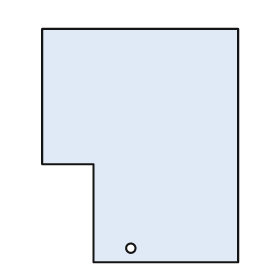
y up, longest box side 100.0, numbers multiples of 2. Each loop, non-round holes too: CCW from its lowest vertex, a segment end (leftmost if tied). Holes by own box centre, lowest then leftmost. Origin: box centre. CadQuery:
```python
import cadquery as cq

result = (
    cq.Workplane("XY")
    .moveTo(-20.0, -50.0)
    .lineTo(42.0, -50.0)
    .lineTo(42.0, 50.0)
    .lineTo(-42.0, 50.0)
    .lineTo(-42.0, -8.0)
    .lineTo(-20.0, -8.0)
    .close()
    .moveTo(-4.0, -44.0)
    .circle(2.0)
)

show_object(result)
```